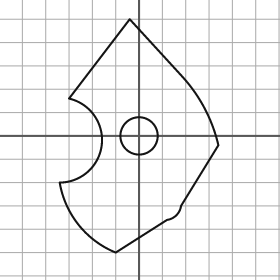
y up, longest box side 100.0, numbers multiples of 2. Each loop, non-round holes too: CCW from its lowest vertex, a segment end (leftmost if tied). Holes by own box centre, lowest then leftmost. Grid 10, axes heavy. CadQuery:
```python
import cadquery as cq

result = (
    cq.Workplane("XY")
    .moveTo(-10.0, -50.0)
    .lineTo(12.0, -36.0)
    .threePointArc((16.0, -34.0), (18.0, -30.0))
    .lineTo(34.0, -4.0)
    .threePointArc((28.0, 12.0), (18.0, 26.0))
    .lineTo(-4.0, 50.0)
    .lineTo(-30.0, 16.0)
    .threePointArc((-16.0, -4.0), (-34.0, -20.0))
    .threePointArc((-26.0, -38.0), (-10.0, -50.0))
    .close()
    .moveTo(0.0, 0.0)
    .circle(8.0)
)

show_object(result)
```